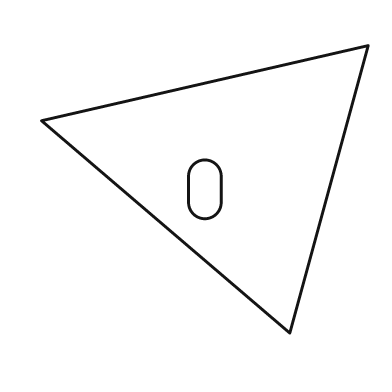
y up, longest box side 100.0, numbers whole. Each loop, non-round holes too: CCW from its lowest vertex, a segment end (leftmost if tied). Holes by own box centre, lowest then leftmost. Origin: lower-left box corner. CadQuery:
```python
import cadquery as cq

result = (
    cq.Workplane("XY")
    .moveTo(76.0, 0.0)
    .lineTo(100.0, 88.0)
    .lineTo(0.0, 65.0)
    .close()
    .moveTo(45.0, 40.0)
    .threePointArc((50.0, 35.0), (55.0, 40.0))
    .lineTo(55.0, 48.0)
    .threePointArc((50.0, 53.0), (45.0, 48.0))
    .close()
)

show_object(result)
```